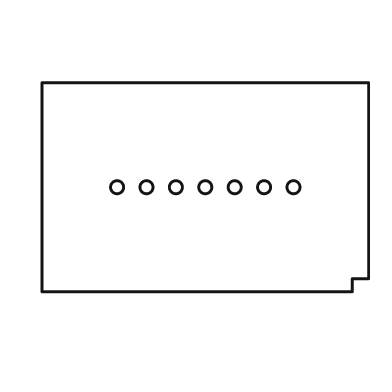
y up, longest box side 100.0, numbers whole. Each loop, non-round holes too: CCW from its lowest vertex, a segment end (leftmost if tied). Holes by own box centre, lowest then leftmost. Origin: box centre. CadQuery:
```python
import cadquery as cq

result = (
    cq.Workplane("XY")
    .moveTo(-50.0, -32.0)
    .lineTo(45.0, -32.0)
    .lineTo(45.0, -28.0)
    .lineTo(50.0, -28.0)
    .lineTo(50.0, 32.0)
    .lineTo(-50.0, 32.0)
    .close()
    .moveTo(-27.0, 0.0)
    .circle(2.0)
    .moveTo(-18.0, 0.0)
    .circle(2.0)
    .moveTo(-9.0, 0.0)
    .circle(2.0)
    .moveTo(0.0, 0.0)
    .circle(2.0)
    .moveTo(9.0, 0.0)
    .circle(2.0)
    .moveTo(18.0, 0.0)
    .circle(2.0)
    .moveTo(27.0, 0.0)
    .circle(2.0)
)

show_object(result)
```